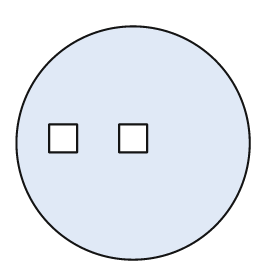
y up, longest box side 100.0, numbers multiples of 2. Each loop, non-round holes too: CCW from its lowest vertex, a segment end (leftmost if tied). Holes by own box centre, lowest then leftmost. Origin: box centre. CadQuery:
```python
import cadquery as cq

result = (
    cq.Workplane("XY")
    .moveTo(0.0, 0.0)
    .circle(50.0)
    .moveTo(-36.0, -4.0)
    .lineTo(-24.0, -4.0)
    .lineTo(-24.0, 8.0)
    .lineTo(-36.0, 8.0)
    .close()
    .moveTo(-6.0, -4.0)
    .lineTo(6.0, -4.0)
    .lineTo(6.0, 8.0)
    .lineTo(-6.0, 8.0)
    .close()
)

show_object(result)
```